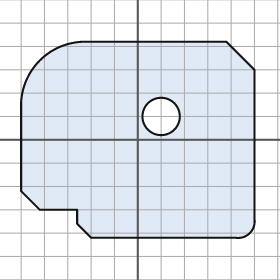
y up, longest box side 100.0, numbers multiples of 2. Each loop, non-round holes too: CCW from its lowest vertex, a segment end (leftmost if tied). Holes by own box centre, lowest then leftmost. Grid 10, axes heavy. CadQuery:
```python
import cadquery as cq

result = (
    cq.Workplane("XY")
    .moveTo(-20.0, -42.0)
    .lineTo(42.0, -42.0)
    .threePointArc((48.0, -40.0), (50.0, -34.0))
    .lineTo(50.0, 30.0)
    .lineTo(38.0, 42.0)
    .lineTo(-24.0, 42.0)
    .threePointArc((-42.0, 34.0), (-50.0, 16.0))
    .lineTo(-50.0, -22.0)
    .lineTo(-42.0, -30.0)
    .lineTo(-26.0, -30.0)
    .lineTo(-26.0, -36.0)
    .close()
    .moveTo(10.0, 10.0)
    .circle(8.0)
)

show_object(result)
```